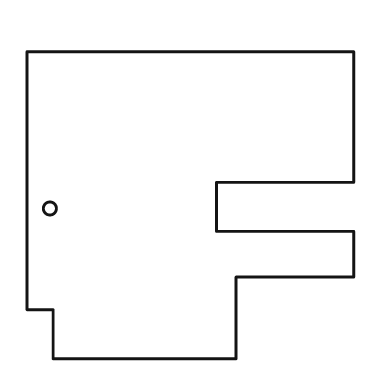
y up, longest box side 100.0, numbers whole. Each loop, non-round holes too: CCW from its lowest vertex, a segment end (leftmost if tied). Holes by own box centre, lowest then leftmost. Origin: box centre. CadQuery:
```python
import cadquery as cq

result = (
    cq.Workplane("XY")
    .moveTo(-42.0, -47.0)
    .lineTo(14.0, -47.0)
    .lineTo(14.0, -22.0)
    .lineTo(50.0, -22.0)
    .lineTo(50.0, -8.0)
    .lineTo(8.0, -8.0)
    .lineTo(8.0, 7.0)
    .lineTo(50.0, 7.0)
    .lineTo(50.0, 47.0)
    .lineTo(-50.0, 47.0)
    .lineTo(-50.0, -32.0)
    .lineTo(-42.0, -32.0)
    .close()
    .moveTo(-43.0, -1.0)
    .circle(2.0)
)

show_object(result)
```